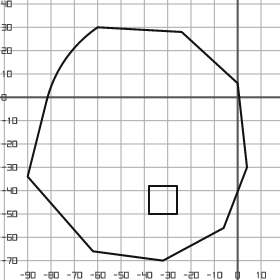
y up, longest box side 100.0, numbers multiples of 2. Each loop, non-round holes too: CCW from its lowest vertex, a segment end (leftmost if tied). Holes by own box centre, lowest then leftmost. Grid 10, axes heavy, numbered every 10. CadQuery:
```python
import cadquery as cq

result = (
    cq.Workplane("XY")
    .moveTo(-32.0, -70.0)
    .lineTo(-6.0, -56.0)
    .lineTo(4.0, -30.0)
    .lineTo(0.0, 6.0)
    .lineTo(-24.0, 28.0)
    .lineTo(-60.0, 30.0)
    .threePointArc((-74.0, 16.0), (-82.0, -2.0))
    .lineTo(-90.0, -34.0)
    .lineTo(-62.0, -66.0)
    .close()
    .moveTo(-38.0, -50.0)
    .lineTo(-26.0, -50.0)
    .lineTo(-26.0, -38.0)
    .lineTo(-38.0, -38.0)
    .close()
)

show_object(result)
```